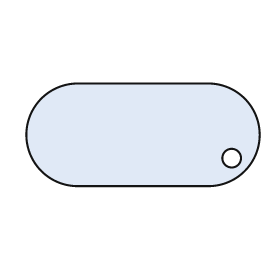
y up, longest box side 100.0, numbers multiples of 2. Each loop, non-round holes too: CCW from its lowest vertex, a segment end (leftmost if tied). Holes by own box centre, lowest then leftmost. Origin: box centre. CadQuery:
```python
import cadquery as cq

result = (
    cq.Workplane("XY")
    .moveTo(-28.0, -22.0)
    .lineTo(28.0, -22.0)
    .threePointArc((50.0, 0.0), (28.0, 22.0))
    .lineTo(-28.0, 22.0)
    .threePointArc((-50.0, 0.0), (-28.0, -22.0))
    .close()
    .moveTo(38.0, -10.0)
    .circle(4.0)
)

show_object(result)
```